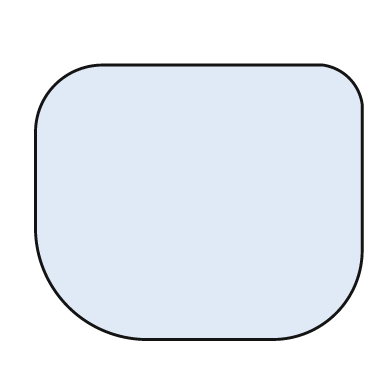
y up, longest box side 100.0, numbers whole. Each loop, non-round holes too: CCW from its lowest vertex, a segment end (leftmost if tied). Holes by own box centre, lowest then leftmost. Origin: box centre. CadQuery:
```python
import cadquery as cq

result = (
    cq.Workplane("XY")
    .moveTo(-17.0, -42.0)
    .lineTo(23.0, -42.0)
    .threePointArc((42.0, -34.0), (50.0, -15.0))
    .lineTo(50.0, 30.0)
    .threePointArc((46.0, 38.0), (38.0, 42.0))
    .lineTo(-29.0, 42.0)
    .threePointArc((-44.0, 36.0), (-50.0, 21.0))
    .lineTo(-50.0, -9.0)
    .threePointArc((-40.0, -32.0), (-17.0, -42.0))
    .close()
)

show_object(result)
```